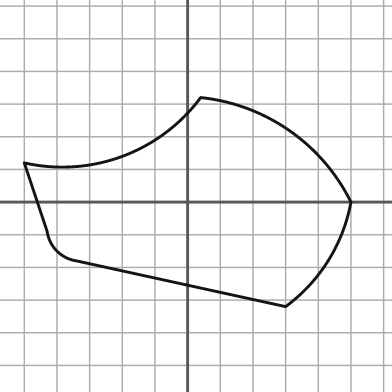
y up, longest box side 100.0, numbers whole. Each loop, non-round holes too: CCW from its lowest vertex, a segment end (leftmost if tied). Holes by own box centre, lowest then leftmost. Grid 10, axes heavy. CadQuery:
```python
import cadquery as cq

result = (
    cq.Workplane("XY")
    .moveTo(30.0, -32.0)
    .threePointArc((43.0, -18.0), (50.0, 0.0))
    .threePointArc((31.0, 22.0), (4.0, 32.0))
    .threePointArc((-20.0, 14.0), (-50.0, 12.0))
    .lineTo(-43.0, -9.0)
    .threePointArc((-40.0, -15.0), (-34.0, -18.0))
    .close()
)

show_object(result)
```